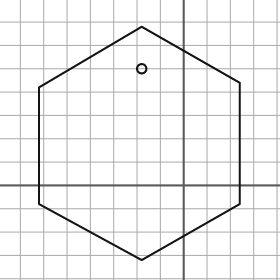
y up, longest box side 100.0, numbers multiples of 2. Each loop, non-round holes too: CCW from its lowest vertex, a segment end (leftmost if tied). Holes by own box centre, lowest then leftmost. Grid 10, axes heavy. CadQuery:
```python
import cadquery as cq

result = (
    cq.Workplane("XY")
    .moveTo(-18.0, -32.0)
    .lineTo(24.0, -8.0)
    .lineTo(24.0, 44.0)
    .lineTo(-18.0, 68.0)
    .lineTo(-62.0, 42.0)
    .lineTo(-62.0, -8.0)
    .close()
    .moveTo(-18.0, 50.0)
    .circle(2.0)
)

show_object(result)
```